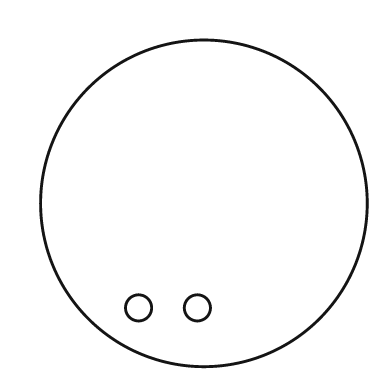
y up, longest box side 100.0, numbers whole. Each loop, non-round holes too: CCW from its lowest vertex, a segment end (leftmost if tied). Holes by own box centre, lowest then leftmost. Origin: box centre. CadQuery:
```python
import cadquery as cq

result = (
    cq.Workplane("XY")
    .moveTo(0.0, 0.0)
    .circle(50.0)
    .moveTo(-20.0, -32.0)
    .circle(4.0)
    .moveTo(-2.0, -32.0)
    .circle(4.0)
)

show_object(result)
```